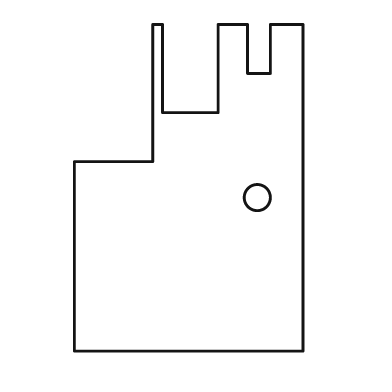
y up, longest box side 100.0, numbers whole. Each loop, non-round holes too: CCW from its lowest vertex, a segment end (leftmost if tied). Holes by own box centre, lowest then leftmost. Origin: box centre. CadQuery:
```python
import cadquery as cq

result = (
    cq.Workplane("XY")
    .moveTo(-35.0, -50.0)
    .lineTo(35.0, -50.0)
    .lineTo(35.0, 50.0)
    .lineTo(25.0, 50.0)
    .lineTo(25.0, 35.0)
    .lineTo(18.0, 35.0)
    .lineTo(18.0, 50.0)
    .lineTo(9.0, 50.0)
    .lineTo(9.0, 23.0)
    .lineTo(-8.0, 23.0)
    .lineTo(-8.0, 50.0)
    .lineTo(-11.0, 50.0)
    .lineTo(-11.0, 8.0)
    .lineTo(-35.0, 8.0)
    .close()
    .moveTo(21.0, -3.0)
    .circle(4.0)
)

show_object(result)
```